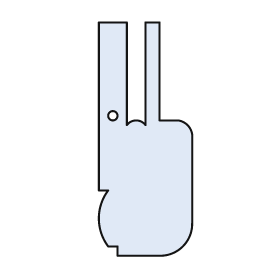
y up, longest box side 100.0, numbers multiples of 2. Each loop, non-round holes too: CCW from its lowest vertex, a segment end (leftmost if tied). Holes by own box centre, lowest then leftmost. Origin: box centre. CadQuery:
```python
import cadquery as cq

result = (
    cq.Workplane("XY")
    .moveTo(-12.0, -50.0)
    .lineTo(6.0, -50.0)
    .threePointArc((16.0, -46.0), (20.0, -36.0))
    .lineTo(20.0, 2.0)
    .threePointArc((18.0, 6.0), (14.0, 8.0))
    .lineTo(6.0, 8.0)
    .lineTo(6.0, 50.0)
    .lineTo(0.0, 50.0)
    .lineTo(0.0, 6.0)
    .threePointArc((-4.0, 8.0), (-8.0, 6.0))
    .lineTo(-8.0, 50.0)
    .lineTo(-20.0, 50.0)
    .lineTo(-20.0, -22.0)
    .lineTo(-16.0, -22.0)
    .threePointArc((-20.0, -34.0), (-16.0, -46.0))
    .lineTo(-12.0, -46.0)
    .close()
    .moveTo(-14.0, 10.0)
    .circle(2.0)
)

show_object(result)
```